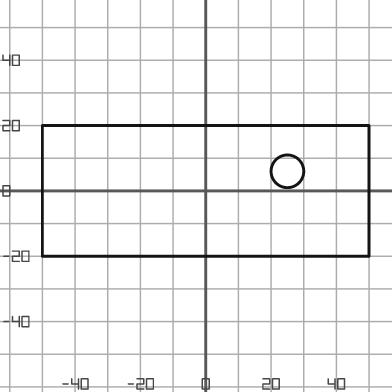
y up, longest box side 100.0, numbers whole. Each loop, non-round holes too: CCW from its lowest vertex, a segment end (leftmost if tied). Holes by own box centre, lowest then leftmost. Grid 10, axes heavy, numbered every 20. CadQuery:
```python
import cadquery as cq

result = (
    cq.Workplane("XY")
    .moveTo(-50.0, -20.0)
    .lineTo(50.0, -20.0)
    .lineTo(50.0, 20.0)
    .lineTo(-50.0, 20.0)
    .close()
    .moveTo(25.0, 6.0)
    .circle(5.0)
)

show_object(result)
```